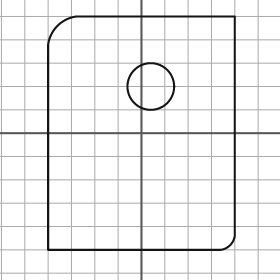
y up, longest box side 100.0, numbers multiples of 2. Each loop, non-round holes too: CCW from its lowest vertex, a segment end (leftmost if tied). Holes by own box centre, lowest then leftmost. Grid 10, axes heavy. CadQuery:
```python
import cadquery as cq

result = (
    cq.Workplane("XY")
    .moveTo(-40.0, -50.0)
    .lineTo(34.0, -50.0)
    .threePointArc((38.0, -48.0), (40.0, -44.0))
    .lineTo(40.0, 50.0)
    .lineTo(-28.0, 50.0)
    .threePointArc((-36.0, 46.0), (-40.0, 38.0))
    .close()
    .moveTo(4.0, 20.0)
    .circle(10.0)
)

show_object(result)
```